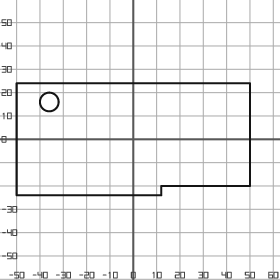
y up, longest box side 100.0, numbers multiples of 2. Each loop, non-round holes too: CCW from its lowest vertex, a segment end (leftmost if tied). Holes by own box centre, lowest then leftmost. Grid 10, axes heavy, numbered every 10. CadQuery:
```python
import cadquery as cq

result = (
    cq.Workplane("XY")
    .moveTo(-50.0, -24.0)
    .lineTo(12.0, -24.0)
    .lineTo(12.0, -20.0)
    .lineTo(50.0, -20.0)
    .lineTo(50.0, 24.0)
    .lineTo(-50.0, 24.0)
    .close()
    .moveTo(-36.0, 16.0)
    .circle(4.0)
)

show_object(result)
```